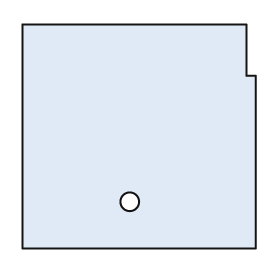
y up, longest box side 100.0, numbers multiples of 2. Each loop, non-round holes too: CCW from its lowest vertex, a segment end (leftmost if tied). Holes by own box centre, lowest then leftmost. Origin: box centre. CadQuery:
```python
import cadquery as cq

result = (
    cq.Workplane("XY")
    .moveTo(-50.0, -48.0)
    .lineTo(50.0, -48.0)
    .lineTo(50.0, 26.0)
    .lineTo(46.0, 26.0)
    .lineTo(46.0, 48.0)
    .lineTo(-50.0, 48.0)
    .close()
    .moveTo(-4.0, -28.0)
    .circle(4.0)
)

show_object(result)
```